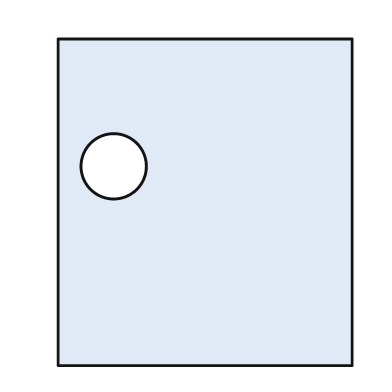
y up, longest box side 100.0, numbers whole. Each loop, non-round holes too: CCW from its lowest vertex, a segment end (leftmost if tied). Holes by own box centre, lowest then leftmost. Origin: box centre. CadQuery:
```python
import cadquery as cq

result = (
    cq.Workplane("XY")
    .moveTo(-45.0, -50.0)
    .lineTo(45.0, -50.0)
    .lineTo(45.0, 50.0)
    .lineTo(-45.0, 50.0)
    .close()
    .moveTo(-28.0, 11.0)
    .circle(10.0)
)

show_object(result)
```